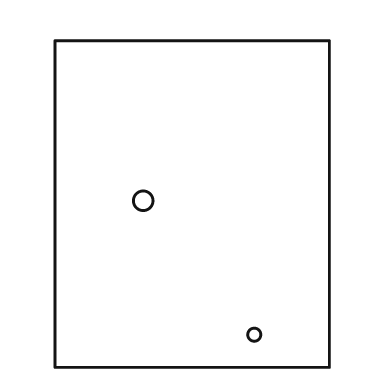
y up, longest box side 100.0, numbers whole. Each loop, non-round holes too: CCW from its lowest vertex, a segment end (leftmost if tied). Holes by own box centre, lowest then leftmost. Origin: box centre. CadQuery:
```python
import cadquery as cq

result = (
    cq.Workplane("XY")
    .moveTo(-42.0, -50.0)
    .lineTo(42.0, -50.0)
    .lineTo(42.0, 50.0)
    .lineTo(-42.0, 50.0)
    .close()
    .moveTo(19.0, -40.0)
    .circle(2.0)
    .moveTo(-15.0, 1.0)
    .circle(3.0)
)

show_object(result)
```